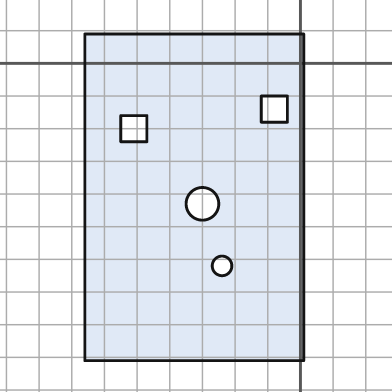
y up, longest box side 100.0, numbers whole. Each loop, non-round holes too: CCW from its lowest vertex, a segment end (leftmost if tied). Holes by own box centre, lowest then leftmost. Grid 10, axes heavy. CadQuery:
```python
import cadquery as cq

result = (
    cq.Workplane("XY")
    .moveTo(-66.0, -91.0)
    .lineTo(1.0, -91.0)
    .lineTo(1.0, 9.0)
    .lineTo(-66.0, 9.0)
    .close()
    .moveTo(-24.0, -62.0)
    .circle(3.0)
    .moveTo(-30.0, -43.0)
    .circle(5.0)
    .moveTo(-55.0, -24.0)
    .lineTo(-47.0, -24.0)
    .lineTo(-47.0, -16.0)
    .lineTo(-55.0, -16.0)
    .close()
    .moveTo(-12.0, -18.0)
    .lineTo(-4.0, -18.0)
    .lineTo(-4.0, -10.0)
    .lineTo(-12.0, -10.0)
    .close()
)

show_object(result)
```